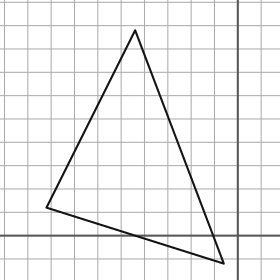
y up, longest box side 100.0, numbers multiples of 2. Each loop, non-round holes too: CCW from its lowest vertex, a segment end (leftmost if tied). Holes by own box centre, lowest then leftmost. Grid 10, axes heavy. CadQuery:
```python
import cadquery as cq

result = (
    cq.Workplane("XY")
    .moveTo(-6.0, -12.0)
    .lineTo(-44.0, 88.0)
    .lineTo(-82.0, 12.0)
    .close()
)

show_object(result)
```